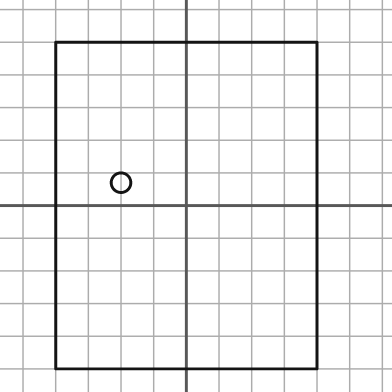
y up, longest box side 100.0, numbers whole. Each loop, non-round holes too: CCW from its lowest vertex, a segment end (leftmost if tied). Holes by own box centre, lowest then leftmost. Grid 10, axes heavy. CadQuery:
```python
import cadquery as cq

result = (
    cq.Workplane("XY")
    .moveTo(-40.0, -50.0)
    .lineTo(40.0, -50.0)
    .lineTo(40.0, 50.0)
    .lineTo(-40.0, 50.0)
    .close()
    .moveTo(-20.0, 7.0)
    .circle(3.0)
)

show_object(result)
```